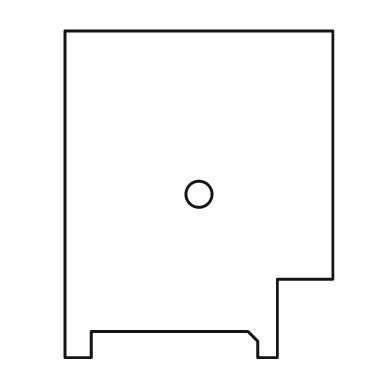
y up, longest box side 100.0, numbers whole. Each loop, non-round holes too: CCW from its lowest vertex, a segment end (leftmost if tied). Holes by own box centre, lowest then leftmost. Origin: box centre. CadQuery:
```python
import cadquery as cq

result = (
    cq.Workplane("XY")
    .moveTo(-41.0, -50.0)
    .lineTo(-33.0, -50.0)
    .lineTo(-33.0, -42.0)
    .lineTo(15.0, -42.0)
    .lineTo(18.0, -45.0)
    .lineTo(18.0, -50.0)
    .lineTo(24.0, -50.0)
    .lineTo(24.0, -26.0)
    .lineTo(41.0, -26.0)
    .lineTo(41.0, 50.0)
    .lineTo(-41.0, 50.0)
    .close()
    .moveTo(0.0, 0.0)
    .circle(4.0)
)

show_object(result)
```